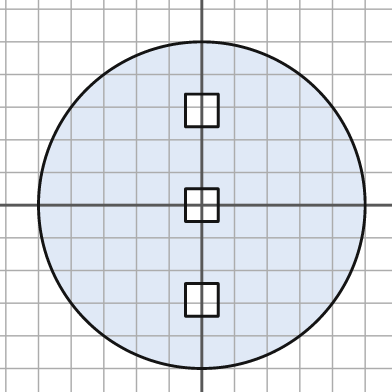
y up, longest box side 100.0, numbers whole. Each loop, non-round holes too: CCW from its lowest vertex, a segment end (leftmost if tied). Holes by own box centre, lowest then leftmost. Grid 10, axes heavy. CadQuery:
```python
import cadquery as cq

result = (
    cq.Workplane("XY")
    .moveTo(0.0, 0.0)
    .circle(50.0)
    .moveTo(-5.0, -34.0)
    .lineTo(5.0, -34.0)
    .lineTo(5.0, -24.0)
    .lineTo(-5.0, -24.0)
    .close()
    .moveTo(-5.0, -5.0)
    .lineTo(5.0, -5.0)
    .lineTo(5.0, 5.0)
    .lineTo(-5.0, 5.0)
    .close()
    .moveTo(-5.0, 24.0)
    .lineTo(5.0, 24.0)
    .lineTo(5.0, 34.0)
    .lineTo(-5.0, 34.0)
    .close()
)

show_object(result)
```